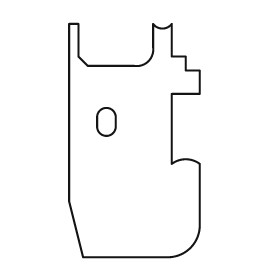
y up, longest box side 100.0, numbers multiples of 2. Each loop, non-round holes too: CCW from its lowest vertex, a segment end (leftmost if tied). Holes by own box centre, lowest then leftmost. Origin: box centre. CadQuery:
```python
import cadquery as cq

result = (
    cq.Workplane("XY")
    .moveTo(-22.0, -50.0)
    .lineTo(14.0, -50.0)
    .threePointArc((24.0, -46.0), (28.0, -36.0))
    .lineTo(28.0, -10.0)
    .threePointArc((22.0, -8.0), (16.0, -10.0))
    .lineTo(16.0, 20.0)
    .lineTo(28.0, 20.0)
    .lineTo(28.0, 30.0)
    .lineTo(22.0, 30.0)
    .lineTo(22.0, 36.0)
    .lineTo(16.0, 36.0)
    .lineTo(16.0, 50.0)
    .threePointArc((12.0, 48.0), (8.0, 50.0))
    .lineTo(8.0, 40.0)
    .threePointArc((6.0, 34.0), (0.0, 32.0))
    .lineTo(-20.0, 32.0)
    .lineTo(-24.0, 36.0)
    .lineTo(-24.0, 50.0)
    .lineTo(-28.0, 50.0)
    .lineTo(-28.0, -26.0)
    .close()
    .moveTo(-16.0, 6.0)
    .threePointArc((-12.0, 2.0), (-8.0, 6.0))
    .lineTo(-8.0, 10.0)
    .threePointArc((-12.0, 14.0), (-16.0, 10.0))
    .close()
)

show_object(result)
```